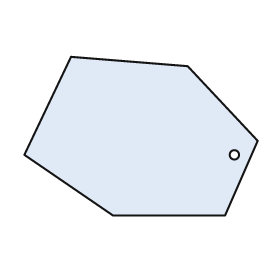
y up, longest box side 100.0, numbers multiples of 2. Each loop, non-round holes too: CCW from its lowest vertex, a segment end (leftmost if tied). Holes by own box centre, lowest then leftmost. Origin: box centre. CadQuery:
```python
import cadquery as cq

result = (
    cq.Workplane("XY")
    .moveTo(-12.0, -34.0)
    .lineTo(36.0, -34.0)
    .lineTo(50.0, -2.0)
    .lineTo(20.0, 30.0)
    .lineTo(-30.0, 34.0)
    .lineTo(-50.0, -8.0)
    .close()
    .moveTo(40.0, -8.0)
    .circle(2.0)
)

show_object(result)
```